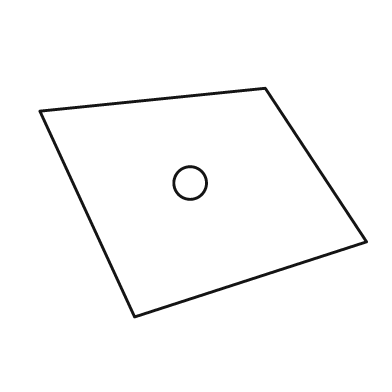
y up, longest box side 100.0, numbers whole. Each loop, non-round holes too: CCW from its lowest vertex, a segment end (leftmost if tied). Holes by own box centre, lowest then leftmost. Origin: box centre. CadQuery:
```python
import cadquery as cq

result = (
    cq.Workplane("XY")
    .moveTo(-21.0, -35.0)
    .lineTo(50.0, -12.0)
    .lineTo(19.0, 35.0)
    .lineTo(-50.0, 28.0)
    .close()
    .moveTo(-4.0, 6.0)
    .circle(5.0)
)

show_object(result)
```